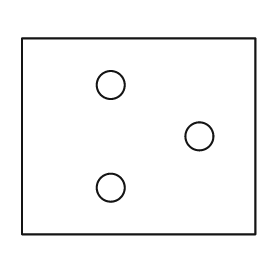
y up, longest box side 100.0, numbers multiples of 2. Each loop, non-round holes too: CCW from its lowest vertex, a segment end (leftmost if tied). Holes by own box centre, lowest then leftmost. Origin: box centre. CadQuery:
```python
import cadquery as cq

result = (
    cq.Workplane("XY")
    .moveTo(-50.0, -42.0)
    .lineTo(50.0, -42.0)
    .lineTo(50.0, 42.0)
    .lineTo(-50.0, 42.0)
    .close()
    .moveTo(-12.0, -22.0)
    .circle(6.0)
    .moveTo(26.0, 0.0)
    .circle(6.0)
    .moveTo(-12.0, 22.0)
    .circle(6.0)
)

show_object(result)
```